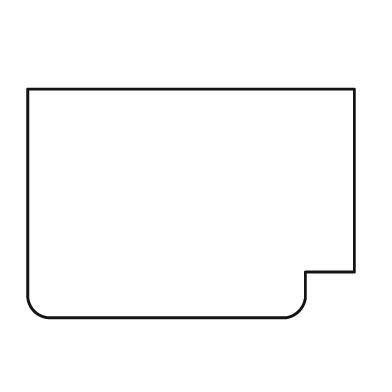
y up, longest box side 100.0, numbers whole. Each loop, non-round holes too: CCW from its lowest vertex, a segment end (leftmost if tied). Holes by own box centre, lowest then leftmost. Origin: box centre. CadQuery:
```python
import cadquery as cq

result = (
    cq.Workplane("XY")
    .moveTo(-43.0, -35.0)
    .lineTo(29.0, -35.0)
    .threePointArc((33.0, -33.0), (35.0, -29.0))
    .lineTo(35.0, -21.0)
    .lineTo(50.0, -21.0)
    .lineTo(50.0, 35.0)
    .lineTo(-50.0, 35.0)
    .lineTo(-50.0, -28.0)
    .threePointArc((-48.0, -33.0), (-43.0, -35.0))
    .close()
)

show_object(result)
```